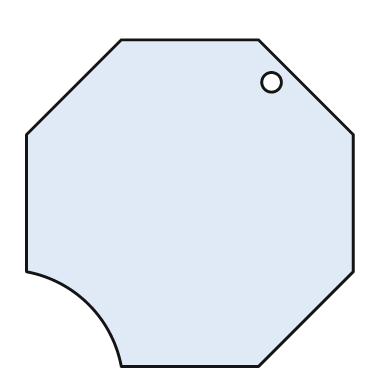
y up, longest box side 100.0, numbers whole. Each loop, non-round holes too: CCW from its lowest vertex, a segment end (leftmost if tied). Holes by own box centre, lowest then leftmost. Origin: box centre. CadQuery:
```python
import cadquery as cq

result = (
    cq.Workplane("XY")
    .moveTo(-21.0, -50.0)
    .lineTo(21.0, -50.0)
    .lineTo(50.0, -21.0)
    .lineTo(50.0, 21.0)
    .lineTo(21.0, 50.0)
    .lineTo(-21.0, 50.0)
    .lineTo(-50.0, 21.0)
    .lineTo(-50.0, -21.0)
    .threePointArc((-31.0, -31.0), (-21.0, -50.0))
    .close()
    .moveTo(25.0, 37.0)
    .circle(3.0)
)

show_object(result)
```